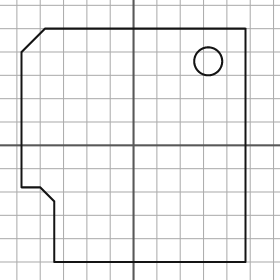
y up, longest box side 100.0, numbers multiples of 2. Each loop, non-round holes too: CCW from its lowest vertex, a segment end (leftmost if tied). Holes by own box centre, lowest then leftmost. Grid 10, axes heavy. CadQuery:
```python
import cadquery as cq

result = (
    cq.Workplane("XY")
    .moveTo(-34.0, -50.0)
    .lineTo(48.0, -50.0)
    .lineTo(48.0, 50.0)
    .lineTo(-38.0, 50.0)
    .lineTo(-48.0, 40.0)
    .lineTo(-48.0, -18.0)
    .lineTo(-40.0, -18.0)
    .lineTo(-34.0, -24.0)
    .close()
    .moveTo(32.0, 36.0)
    .circle(6.0)
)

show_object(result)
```